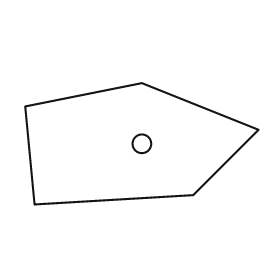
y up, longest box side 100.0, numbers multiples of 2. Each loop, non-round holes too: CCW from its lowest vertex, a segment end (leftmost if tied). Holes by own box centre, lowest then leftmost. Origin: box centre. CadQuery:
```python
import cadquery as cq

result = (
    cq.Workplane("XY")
    .moveTo(-46.0, -26.0)
    .lineTo(22.0, -22.0)
    .lineTo(50.0, 6.0)
    .lineTo(0.0, 26.0)
    .lineTo(-50.0, 16.0)
    .close()
    .moveTo(0.0, 0.0)
    .circle(4.0)
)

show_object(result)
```